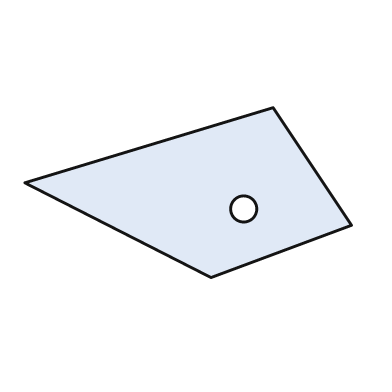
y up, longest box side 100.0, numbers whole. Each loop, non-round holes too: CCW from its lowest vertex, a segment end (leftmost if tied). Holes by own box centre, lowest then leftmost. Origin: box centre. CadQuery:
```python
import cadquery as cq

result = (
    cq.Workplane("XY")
    .moveTo(7.0, -26.0)
    .lineTo(50.0, -10.0)
    .lineTo(26.0, 26.0)
    .lineTo(-50.0, 3.0)
    .close()
    .moveTo(17.0, -5.0)
    .circle(4.0)
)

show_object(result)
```